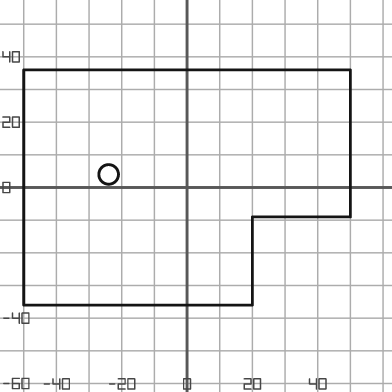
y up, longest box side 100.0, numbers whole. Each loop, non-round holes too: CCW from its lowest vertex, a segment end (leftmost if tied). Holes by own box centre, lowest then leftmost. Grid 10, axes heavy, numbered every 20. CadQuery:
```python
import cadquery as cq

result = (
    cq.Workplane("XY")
    .moveTo(-50.0, -36.0)
    .lineTo(20.0, -36.0)
    .lineTo(20.0, -9.0)
    .lineTo(50.0, -9.0)
    .lineTo(50.0, 36.0)
    .lineTo(-50.0, 36.0)
    .close()
    .moveTo(-24.0, 4.0)
    .circle(3.0)
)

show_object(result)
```